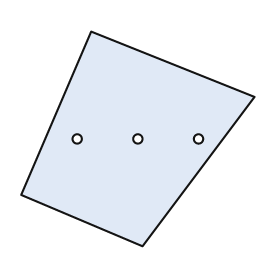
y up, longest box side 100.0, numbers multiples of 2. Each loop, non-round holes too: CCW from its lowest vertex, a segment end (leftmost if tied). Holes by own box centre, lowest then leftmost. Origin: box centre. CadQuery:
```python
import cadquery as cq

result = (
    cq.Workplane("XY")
    .moveTo(2.0, -46.0)
    .lineTo(50.0, 18.0)
    .lineTo(-20.0, 46.0)
    .lineTo(-50.0, -24.0)
    .close()
    .moveTo(-26.0, 0.0)
    .circle(2.0)
    .moveTo(0.0, 0.0)
    .circle(2.0)
    .moveTo(26.0, 0.0)
    .circle(2.0)
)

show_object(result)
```